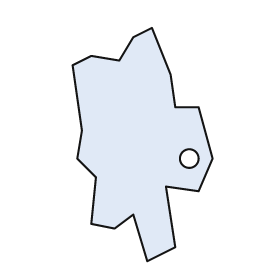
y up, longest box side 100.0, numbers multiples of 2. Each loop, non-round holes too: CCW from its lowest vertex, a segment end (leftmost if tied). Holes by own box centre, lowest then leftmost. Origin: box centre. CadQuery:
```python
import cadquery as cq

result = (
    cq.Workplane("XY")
    .moveTo(2.0, -50.0)
    .lineTo(14.0, -44.0)
    .lineTo(10.0, -18.0)
    .lineTo(24.0, -20.0)
    .lineTo(30.0, -6.0)
    .lineTo(24.0, 16.0)
    .lineTo(14.0, 16.0)
    .lineTo(12.0, 30.0)
    .lineTo(4.0, 50.0)
    .lineTo(-4.0, 46.0)
    .lineTo(-10.0, 36.0)
    .lineTo(-22.0, 38.0)
    .lineTo(-30.0, 34.0)
    .lineTo(-26.0, 6.0)
    .lineTo(-28.0, -6.0)
    .lineTo(-20.0, -14.0)
    .lineTo(-22.0, -34.0)
    .lineTo(-12.0, -36.0)
    .lineTo(-4.0, -30.0)
    .close()
    .moveTo(20.0, -6.0)
    .circle(4.0)
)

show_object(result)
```